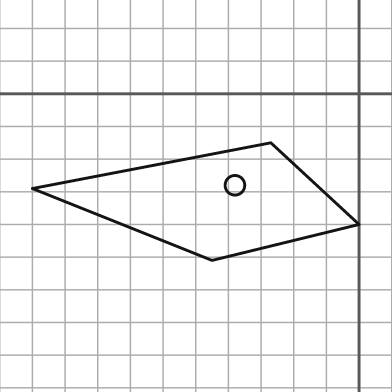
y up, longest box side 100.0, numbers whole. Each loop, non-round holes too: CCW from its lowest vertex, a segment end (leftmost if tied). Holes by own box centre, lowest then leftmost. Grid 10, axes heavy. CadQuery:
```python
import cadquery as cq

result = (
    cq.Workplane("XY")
    .moveTo(-45.0, -51.0)
    .lineTo(0.0, -40.0)
    .lineTo(-27.0, -15.0)
    .lineTo(-100.0, -29.0)
    .close()
    .moveTo(-38.0, -28.0)
    .circle(3.0)
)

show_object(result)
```